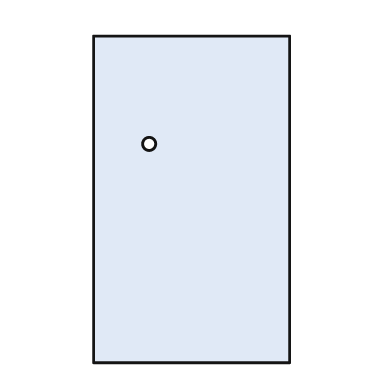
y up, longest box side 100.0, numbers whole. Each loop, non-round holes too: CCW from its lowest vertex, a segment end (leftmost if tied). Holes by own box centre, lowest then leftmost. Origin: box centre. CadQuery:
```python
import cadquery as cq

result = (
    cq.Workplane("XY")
    .moveTo(-30.0, -50.0)
    .lineTo(30.0, -50.0)
    .lineTo(30.0, 50.0)
    .lineTo(-30.0, 50.0)
    .close()
    .moveTo(-13.0, 17.0)
    .circle(2.0)
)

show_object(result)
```